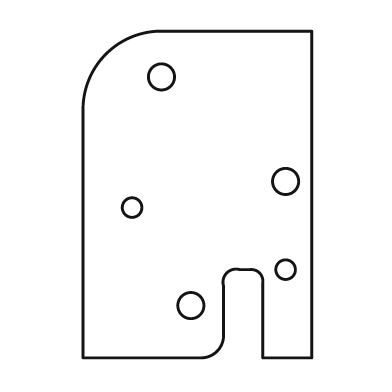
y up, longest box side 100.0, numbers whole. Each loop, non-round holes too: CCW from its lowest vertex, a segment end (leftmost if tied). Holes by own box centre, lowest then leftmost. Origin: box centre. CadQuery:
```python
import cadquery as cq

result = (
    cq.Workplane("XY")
    .moveTo(-35.0, -50.0)
    .lineTo(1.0, -50.0)
    .threePointArc((6.0, -48.0), (8.0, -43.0))
    .lineTo(8.0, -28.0)
    .threePointArc((9.0, -24.0), (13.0, -23.0))
    .lineTo(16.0, -23.0)
    .threePointArc((19.0, -24.0), (20.0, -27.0))
    .lineTo(20.0, -50.0)
    .lineTo(35.0, -50.0)
    .lineTo(35.0, 50.0)
    .lineTo(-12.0, 50.0)
    .threePointArc((-28.0, 43.0), (-35.0, 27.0))
    .close()
    .moveTo(-2.0, -34.0)
    .circle(4.0)
    .moveTo(27.0, -23.0)
    .circle(3.0)
    .moveTo(-20.0, -4.0)
    .circle(3.0)
    .moveTo(27.0, 4.0)
    .circle(4.0)
    .moveTo(-11.0, 36.0)
    .circle(4.0)
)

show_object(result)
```